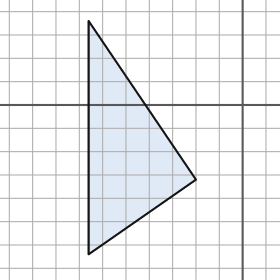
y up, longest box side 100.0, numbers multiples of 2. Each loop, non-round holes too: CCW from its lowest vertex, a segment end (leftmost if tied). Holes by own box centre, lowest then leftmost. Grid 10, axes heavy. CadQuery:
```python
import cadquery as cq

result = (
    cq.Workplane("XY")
    .moveTo(-66.0, -64.0)
    .lineTo(-20.0, -32.0)
    .lineTo(-66.0, 36.0)
    .close()
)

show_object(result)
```